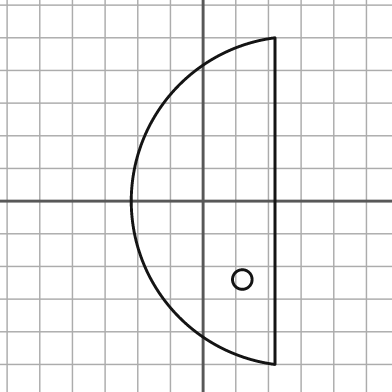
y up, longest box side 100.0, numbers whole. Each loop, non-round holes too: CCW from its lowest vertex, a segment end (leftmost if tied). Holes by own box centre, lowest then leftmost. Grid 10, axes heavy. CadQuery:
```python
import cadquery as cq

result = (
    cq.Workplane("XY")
    .moveTo(22.0, -50.0)
    .lineTo(22.0, 50.0)
    .threePointArc((-22.0, 0.0), (22.0, -50.0))
    .close()
    .moveTo(12.0, -24.0)
    .circle(3.0)
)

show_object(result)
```